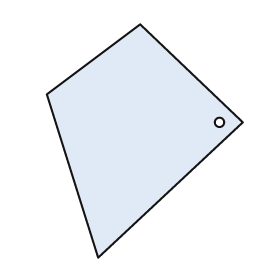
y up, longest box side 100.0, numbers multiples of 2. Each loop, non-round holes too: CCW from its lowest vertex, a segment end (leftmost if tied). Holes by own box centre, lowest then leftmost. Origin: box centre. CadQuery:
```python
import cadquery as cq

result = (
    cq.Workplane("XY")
    .moveTo(-20.0, -50.0)
    .lineTo(42.0, 8.0)
    .lineTo(-2.0, 50.0)
    .lineTo(-42.0, 20.0)
    .close()
    .moveTo(32.0, 8.0)
    .circle(2.0)
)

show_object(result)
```